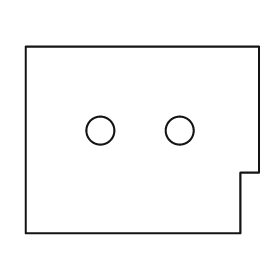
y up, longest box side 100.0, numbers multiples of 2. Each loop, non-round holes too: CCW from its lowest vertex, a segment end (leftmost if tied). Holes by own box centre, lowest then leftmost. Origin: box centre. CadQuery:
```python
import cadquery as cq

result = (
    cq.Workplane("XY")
    .moveTo(-50.0, -40.0)
    .lineTo(42.0, -40.0)
    .lineTo(42.0, -14.0)
    .lineTo(50.0, -14.0)
    .lineTo(50.0, 40.0)
    .lineTo(-50.0, 40.0)
    .close()
    .moveTo(-18.0, 4.0)
    .circle(6.0)
    .moveTo(16.0, 4.0)
    .circle(6.0)
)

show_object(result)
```